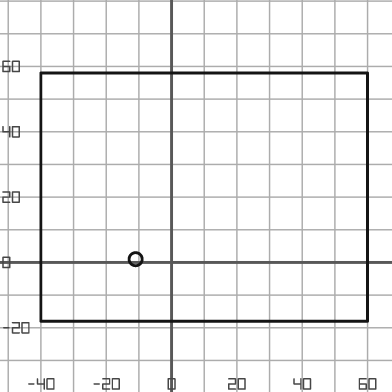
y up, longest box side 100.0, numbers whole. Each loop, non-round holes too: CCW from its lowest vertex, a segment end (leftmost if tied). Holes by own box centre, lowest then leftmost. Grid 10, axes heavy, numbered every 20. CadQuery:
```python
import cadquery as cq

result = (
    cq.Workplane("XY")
    .moveTo(-40.0, -18.0)
    .lineTo(60.0, -18.0)
    .lineTo(60.0, 58.0)
    .lineTo(-40.0, 58.0)
    .close()
    .moveTo(-11.0, 1.0)
    .circle(2.0)
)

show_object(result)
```